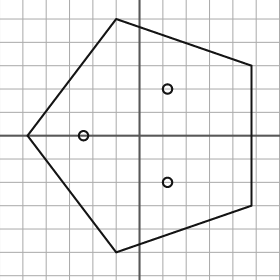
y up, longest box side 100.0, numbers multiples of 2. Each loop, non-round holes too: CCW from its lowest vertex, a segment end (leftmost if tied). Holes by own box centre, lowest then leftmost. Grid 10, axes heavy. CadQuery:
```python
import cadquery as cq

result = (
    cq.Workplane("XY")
    .moveTo(-10.0, -50.0)
    .lineTo(48.0, -30.0)
    .lineTo(48.0, 30.0)
    .lineTo(-10.0, 50.0)
    .lineTo(-48.0, 0.0)
    .close()
    .moveTo(12.0, -20.0)
    .circle(2.0)
    .moveTo(-24.0, 0.0)
    .circle(2.0)
    .moveTo(12.0, 20.0)
    .circle(2.0)
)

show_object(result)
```